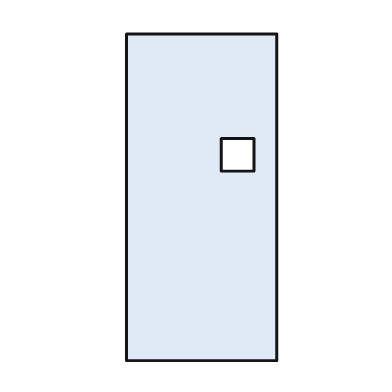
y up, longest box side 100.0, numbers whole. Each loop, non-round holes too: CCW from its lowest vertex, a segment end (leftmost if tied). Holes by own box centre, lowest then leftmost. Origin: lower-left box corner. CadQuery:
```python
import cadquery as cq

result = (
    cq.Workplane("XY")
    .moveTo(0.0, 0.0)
    .lineTo(46.0, 0.0)
    .lineTo(46.0, 100.0)
    .lineTo(0.0, 100.0)
    .close()
    .moveTo(29.0, 58.0)
    .lineTo(39.0, 58.0)
    .lineTo(39.0, 68.0)
    .lineTo(29.0, 68.0)
    .close()
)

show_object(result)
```